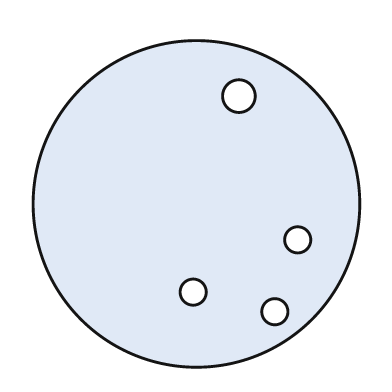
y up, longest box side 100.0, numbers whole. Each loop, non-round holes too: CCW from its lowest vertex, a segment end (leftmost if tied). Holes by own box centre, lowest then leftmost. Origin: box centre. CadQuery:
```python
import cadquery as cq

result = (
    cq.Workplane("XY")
    .moveTo(0.0, 0.0)
    .circle(50.0)
    .moveTo(24.0, -33.0)
    .circle(4.0)
    .moveTo(-1.0, -27.0)
    .circle(4.0)
    .moveTo(31.0, -11.0)
    .circle(4.0)
    .moveTo(13.0, 33.0)
    .circle(5.0)
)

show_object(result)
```